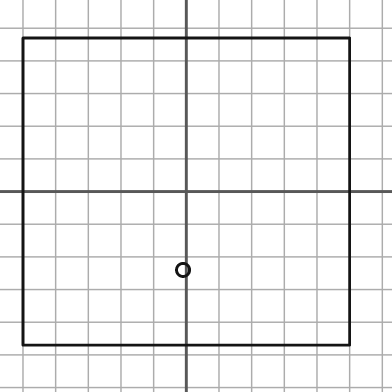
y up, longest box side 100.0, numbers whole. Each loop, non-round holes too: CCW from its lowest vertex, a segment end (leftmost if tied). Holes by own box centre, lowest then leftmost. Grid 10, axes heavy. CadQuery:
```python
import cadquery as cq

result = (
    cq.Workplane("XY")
    .moveTo(-50.0, -47.0)
    .lineTo(50.0, -47.0)
    .lineTo(50.0, 47.0)
    .lineTo(-50.0, 47.0)
    .close()
    .moveTo(-1.0, -24.0)
    .circle(2.0)
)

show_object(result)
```